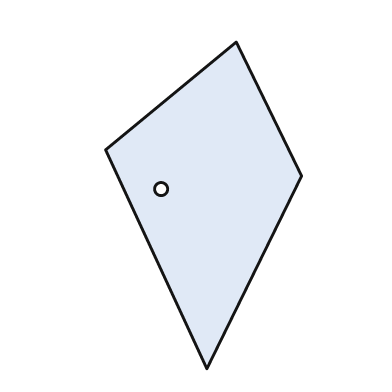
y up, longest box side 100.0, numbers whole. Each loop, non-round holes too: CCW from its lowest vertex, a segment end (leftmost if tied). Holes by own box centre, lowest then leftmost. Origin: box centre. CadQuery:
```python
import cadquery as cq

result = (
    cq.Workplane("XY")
    .moveTo(1.0, -50.0)
    .lineTo(30.0, 9.0)
    .lineTo(10.0, 50.0)
    .lineTo(-30.0, 17.0)
    .close()
    .moveTo(-13.0, 5.0)
    .circle(2.0)
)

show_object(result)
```